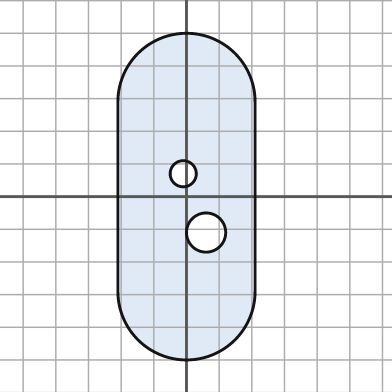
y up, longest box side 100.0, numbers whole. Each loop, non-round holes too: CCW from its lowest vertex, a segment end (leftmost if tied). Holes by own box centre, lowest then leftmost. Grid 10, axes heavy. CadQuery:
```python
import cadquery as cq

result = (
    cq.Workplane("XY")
    .moveTo(-21.0, -29.0)
    .threePointArc((0.0, -50.0), (21.0, -29.0))
    .lineTo(21.0, 29.0)
    .threePointArc((0.0, 50.0), (-21.0, 29.0))
    .close()
    .moveTo(6.0, -11.0)
    .circle(6.0)
    .moveTo(-1.0, 7.0)
    .circle(4.0)
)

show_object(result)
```